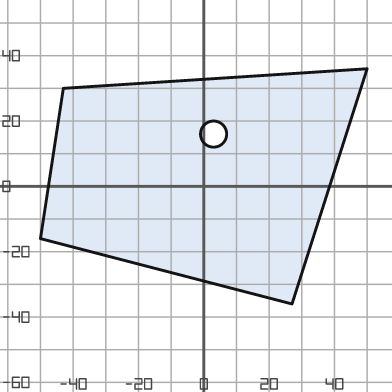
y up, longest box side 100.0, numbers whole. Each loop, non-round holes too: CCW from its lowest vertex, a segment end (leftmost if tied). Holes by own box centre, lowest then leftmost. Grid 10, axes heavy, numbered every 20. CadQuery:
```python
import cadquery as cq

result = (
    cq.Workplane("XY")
    .moveTo(27.0, -36.0)
    .lineTo(50.0, 36.0)
    .lineTo(-43.0, 30.0)
    .lineTo(-50.0, -16.0)
    .close()
    .moveTo(3.0, 16.0)
    .circle(4.0)
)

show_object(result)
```